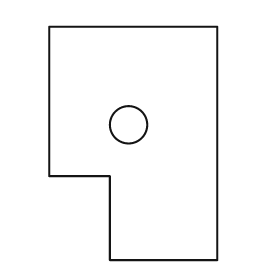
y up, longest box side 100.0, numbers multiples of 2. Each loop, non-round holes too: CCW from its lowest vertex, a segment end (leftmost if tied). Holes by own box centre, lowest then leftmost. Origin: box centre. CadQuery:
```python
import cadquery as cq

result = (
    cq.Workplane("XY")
    .moveTo(-10.0, -50.0)
    .lineTo(36.0, -50.0)
    .lineTo(36.0, 50.0)
    .lineTo(-36.0, 50.0)
    .lineTo(-36.0, -14.0)
    .lineTo(-10.0, -14.0)
    .close()
    .moveTo(-2.0, 8.0)
    .circle(8.0)
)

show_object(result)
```